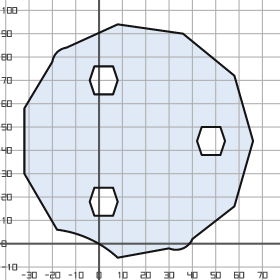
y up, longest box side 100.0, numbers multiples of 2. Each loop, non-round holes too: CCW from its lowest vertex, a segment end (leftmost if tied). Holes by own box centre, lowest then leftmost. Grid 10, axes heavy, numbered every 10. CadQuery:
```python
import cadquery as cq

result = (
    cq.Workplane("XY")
    .moveTo(8.0, -6.0)
    .lineTo(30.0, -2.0)
    .threePointArc((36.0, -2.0), (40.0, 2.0))
    .lineTo(58.0, 16.0)
    .lineTo(66.0, 44.0)
    .lineTo(58.0, 72.0)
    .lineTo(36.0, 90.0)
    .lineTo(8.0, 94.0)
    .lineTo(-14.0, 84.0)
    .threePointArc((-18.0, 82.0), (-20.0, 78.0))
    .lineTo(-32.0, 58.0)
    .lineTo(-32.0, 30.0)
    .lineTo(-18.0, 6.0)
    .threePointArc((-4.0, 2.0), (8.0, -6.0))
    .close()
    .moveTo(-2.0, 12.0)
    .lineTo(6.0, 12.0)
    .lineTo(8.0, 18.0)
    .lineTo(6.0, 24.0)
    .lineTo(-2.0, 24.0)
    .lineTo(-4.0, 18.0)
    .close()
    .moveTo(44.0, 38.0)
    .lineTo(52.0, 38.0)
    .lineTo(54.0, 44.0)
    .lineTo(52.0, 50.0)
    .lineTo(44.0, 50.0)
    .lineTo(42.0, 44.0)
    .close()
    .moveTo(-2.0, 64.0)
    .lineTo(6.0, 64.0)
    .lineTo(8.0, 70.0)
    .lineTo(6.0, 76.0)
    .lineTo(-2.0, 76.0)
    .lineTo(-4.0, 70.0)
    .close()
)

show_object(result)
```